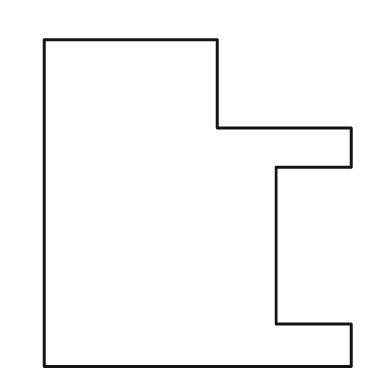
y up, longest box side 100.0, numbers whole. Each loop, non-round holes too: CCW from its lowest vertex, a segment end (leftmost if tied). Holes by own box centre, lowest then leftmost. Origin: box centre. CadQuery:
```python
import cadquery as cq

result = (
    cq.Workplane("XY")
    .moveTo(-47.0, -50.0)
    .lineTo(47.0, -50.0)
    .lineTo(47.0, -37.0)
    .lineTo(24.0, -37.0)
    .lineTo(24.0, 11.0)
    .lineTo(47.0, 11.0)
    .lineTo(47.0, 23.0)
    .lineTo(6.0, 23.0)
    .lineTo(6.0, 50.0)
    .lineTo(-47.0, 50.0)
    .close()
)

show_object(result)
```